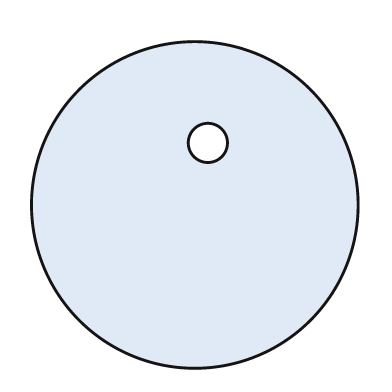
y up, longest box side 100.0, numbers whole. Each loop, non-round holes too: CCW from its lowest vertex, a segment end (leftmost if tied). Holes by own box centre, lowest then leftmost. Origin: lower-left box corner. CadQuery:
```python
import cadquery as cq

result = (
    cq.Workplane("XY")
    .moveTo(50.0, 50.0)
    .circle(50.0)
    .moveTo(54.0, 69.0)
    .circle(6.0)
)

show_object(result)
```